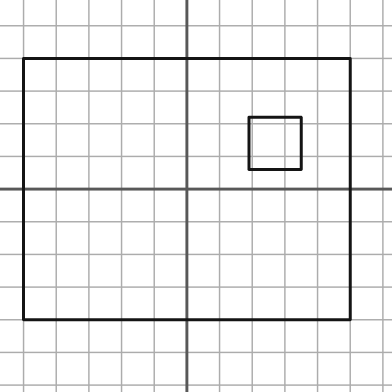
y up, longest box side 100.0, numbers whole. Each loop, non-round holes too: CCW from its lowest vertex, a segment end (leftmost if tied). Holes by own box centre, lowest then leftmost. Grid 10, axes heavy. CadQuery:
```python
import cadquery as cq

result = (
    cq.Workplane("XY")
    .moveTo(-50.0, -40.0)
    .lineTo(50.0, -40.0)
    .lineTo(50.0, 40.0)
    .lineTo(-50.0, 40.0)
    .close()
    .moveTo(19.0, 6.0)
    .lineTo(35.0, 6.0)
    .lineTo(35.0, 22.0)
    .lineTo(19.0, 22.0)
    .close()
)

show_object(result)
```